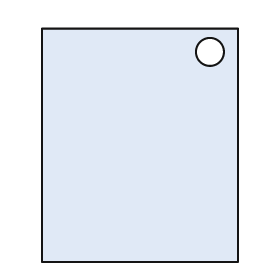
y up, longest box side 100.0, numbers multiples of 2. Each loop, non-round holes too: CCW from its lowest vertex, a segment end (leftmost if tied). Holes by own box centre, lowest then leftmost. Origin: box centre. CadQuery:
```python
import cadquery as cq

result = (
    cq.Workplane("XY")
    .moveTo(-42.0, -50.0)
    .lineTo(42.0, -50.0)
    .lineTo(42.0, 50.0)
    .lineTo(-42.0, 50.0)
    .close()
    .moveTo(30.0, 40.0)
    .circle(6.0)
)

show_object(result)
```